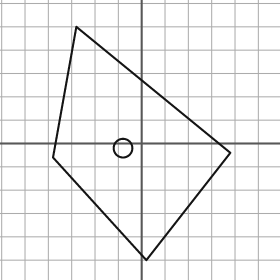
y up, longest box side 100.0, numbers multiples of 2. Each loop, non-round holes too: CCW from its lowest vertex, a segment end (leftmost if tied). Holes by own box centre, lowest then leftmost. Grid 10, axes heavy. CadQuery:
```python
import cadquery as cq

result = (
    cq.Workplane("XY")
    .moveTo(2.0, -50.0)
    .lineTo(38.0, -4.0)
    .lineTo(-28.0, 50.0)
    .lineTo(-38.0, -6.0)
    .close()
    .moveTo(-8.0, -2.0)
    .circle(4.0)
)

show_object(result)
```